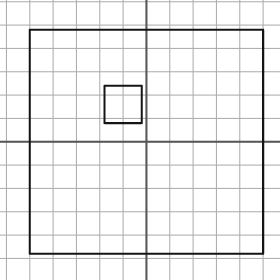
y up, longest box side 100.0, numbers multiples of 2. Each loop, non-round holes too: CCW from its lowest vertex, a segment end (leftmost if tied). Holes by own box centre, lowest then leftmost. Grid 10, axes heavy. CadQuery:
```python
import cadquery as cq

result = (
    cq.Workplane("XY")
    .moveTo(-50.0, -48.0)
    .lineTo(50.0, -48.0)
    .lineTo(50.0, 48.0)
    .lineTo(-50.0, 48.0)
    .close()
    .moveTo(-18.0, 8.0)
    .lineTo(-2.0, 8.0)
    .lineTo(-2.0, 24.0)
    .lineTo(-18.0, 24.0)
    .close()
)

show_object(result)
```